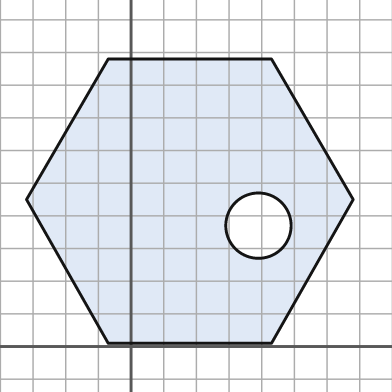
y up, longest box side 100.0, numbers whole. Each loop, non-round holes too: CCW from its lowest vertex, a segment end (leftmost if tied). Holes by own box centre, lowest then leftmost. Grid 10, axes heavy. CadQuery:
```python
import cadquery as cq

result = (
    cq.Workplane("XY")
    .moveTo(-7.0, 1.0)
    .lineTo(43.0, 1.0)
    .lineTo(68.0, 45.0)
    .lineTo(43.0, 88.0)
    .lineTo(-7.0, 88.0)
    .lineTo(-32.0, 45.0)
    .close()
    .moveTo(39.0, 37.0)
    .circle(10.0)
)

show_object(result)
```